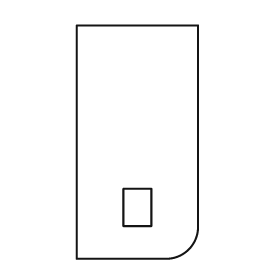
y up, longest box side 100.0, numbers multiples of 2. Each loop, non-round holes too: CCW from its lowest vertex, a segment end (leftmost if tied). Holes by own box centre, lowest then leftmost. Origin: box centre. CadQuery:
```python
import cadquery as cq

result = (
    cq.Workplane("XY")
    .moveTo(-26.0, -50.0)
    .lineTo(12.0, -50.0)
    .threePointArc((22.0, -46.0), (26.0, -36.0))
    .lineTo(26.0, 50.0)
    .lineTo(-26.0, 50.0)
    .close()
    .moveTo(-6.0, -36.0)
    .lineTo(6.0, -36.0)
    .lineTo(6.0, -20.0)
    .lineTo(-6.0, -20.0)
    .close()
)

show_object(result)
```